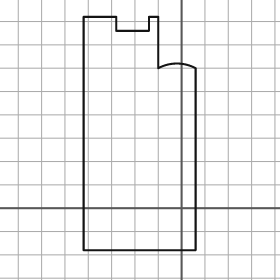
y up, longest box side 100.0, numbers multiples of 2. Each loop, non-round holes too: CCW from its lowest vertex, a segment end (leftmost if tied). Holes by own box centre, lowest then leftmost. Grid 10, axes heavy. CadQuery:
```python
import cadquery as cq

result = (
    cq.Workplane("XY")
    .moveTo(-42.0, -18.0)
    .lineTo(6.0, -18.0)
    .lineTo(6.0, 60.0)
    .threePointArc((-2.0, 62.0), (-10.0, 60.0))
    .lineTo(-10.0, 82.0)
    .lineTo(-14.0, 82.0)
    .lineTo(-14.0, 76.0)
    .lineTo(-28.0, 76.0)
    .lineTo(-28.0, 82.0)
    .lineTo(-42.0, 82.0)
    .close()
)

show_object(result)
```